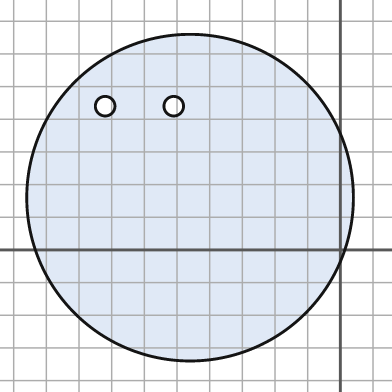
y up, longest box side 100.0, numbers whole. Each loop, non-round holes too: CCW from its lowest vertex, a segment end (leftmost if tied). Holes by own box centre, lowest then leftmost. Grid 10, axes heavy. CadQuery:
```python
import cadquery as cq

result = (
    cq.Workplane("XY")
    .moveTo(-46.0, 16.0)
    .circle(50.0)
    .moveTo(-72.0, 44.0)
    .circle(3.0)
    .moveTo(-51.0, 44.0)
    .circle(3.0)
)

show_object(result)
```